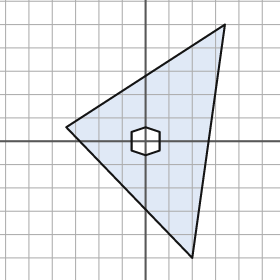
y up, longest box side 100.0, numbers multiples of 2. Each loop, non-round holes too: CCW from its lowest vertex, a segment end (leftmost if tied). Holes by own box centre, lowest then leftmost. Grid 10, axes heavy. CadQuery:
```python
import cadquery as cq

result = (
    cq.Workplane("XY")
    .moveTo(20.0, -50.0)
    .lineTo(34.0, 50.0)
    .lineTo(-34.0, 6.0)
    .close()
    .moveTo(0.0, -6.0)
    .lineTo(6.0, -4.0)
    .lineTo(6.0, 4.0)
    .lineTo(0.0, 6.0)
    .lineTo(-6.0, 4.0)
    .lineTo(-6.0, -4.0)
    .close()
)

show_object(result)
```